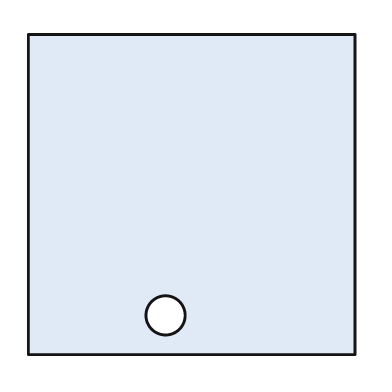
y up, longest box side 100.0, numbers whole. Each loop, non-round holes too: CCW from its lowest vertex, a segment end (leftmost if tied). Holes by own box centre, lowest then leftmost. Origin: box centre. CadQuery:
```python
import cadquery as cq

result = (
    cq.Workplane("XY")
    .moveTo(-50.0, -49.0)
    .lineTo(50.0, -49.0)
    .lineTo(50.0, 49.0)
    .lineTo(-50.0, 49.0)
    .close()
    .moveTo(-8.0, -37.0)
    .circle(6.0)
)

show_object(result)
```